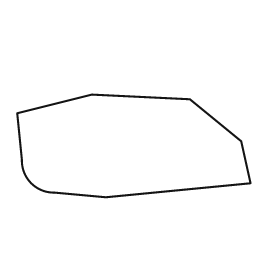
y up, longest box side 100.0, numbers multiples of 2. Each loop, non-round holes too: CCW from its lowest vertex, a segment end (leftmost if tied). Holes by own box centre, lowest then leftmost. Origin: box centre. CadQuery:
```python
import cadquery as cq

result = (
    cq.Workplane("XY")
    .moveTo(-12.0, -22.0)
    .lineTo(50.0, -16.0)
    .lineTo(46.0, 2.0)
    .lineTo(24.0, 20.0)
    .lineTo(-18.0, 22.0)
    .lineTo(-50.0, 14.0)
    .lineTo(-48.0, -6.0)
    .threePointArc((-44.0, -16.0), (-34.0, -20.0))
    .close()
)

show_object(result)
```